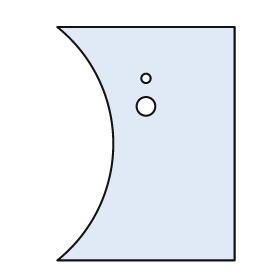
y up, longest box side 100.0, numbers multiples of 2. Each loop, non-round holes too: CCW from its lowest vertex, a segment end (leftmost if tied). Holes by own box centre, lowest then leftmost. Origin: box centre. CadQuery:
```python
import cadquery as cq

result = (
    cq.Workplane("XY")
    .moveTo(-38.0, -50.0)
    .lineTo(38.0, -50.0)
    .lineTo(38.0, 50.0)
    .lineTo(-38.0, 50.0)
    .threePointArc((-14.0, 0.0), (-38.0, -50.0))
    .close()
    .moveTo(0.0, 16.0)
    .circle(4.0)
    .moveTo(0.0, 28.0)
    .circle(2.0)
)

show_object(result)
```